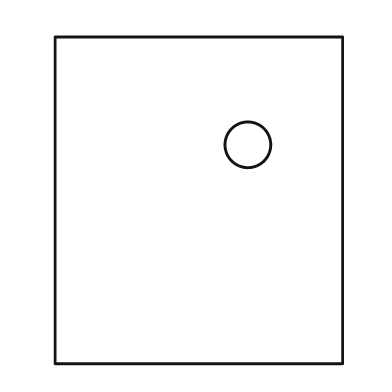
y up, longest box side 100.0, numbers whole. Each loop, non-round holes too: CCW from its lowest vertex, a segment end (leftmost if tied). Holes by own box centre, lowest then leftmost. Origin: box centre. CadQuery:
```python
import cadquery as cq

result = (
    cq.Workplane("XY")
    .moveTo(-44.0, -50.0)
    .lineTo(44.0, -50.0)
    .lineTo(44.0, 50.0)
    .lineTo(-44.0, 50.0)
    .close()
    .moveTo(15.0, 17.0)
    .circle(7.0)
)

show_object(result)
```